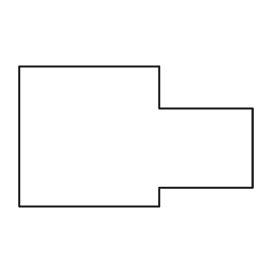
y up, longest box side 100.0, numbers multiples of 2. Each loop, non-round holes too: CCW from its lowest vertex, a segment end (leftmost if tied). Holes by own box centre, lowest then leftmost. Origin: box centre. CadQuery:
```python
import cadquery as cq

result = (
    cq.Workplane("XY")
    .moveTo(-50.0, -30.0)
    .lineTo(10.0, -30.0)
    .lineTo(10.0, -22.0)
    .lineTo(50.0, -22.0)
    .lineTo(50.0, 12.0)
    .lineTo(10.0, 12.0)
    .lineTo(10.0, 30.0)
    .lineTo(-50.0, 30.0)
    .close()
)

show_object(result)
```